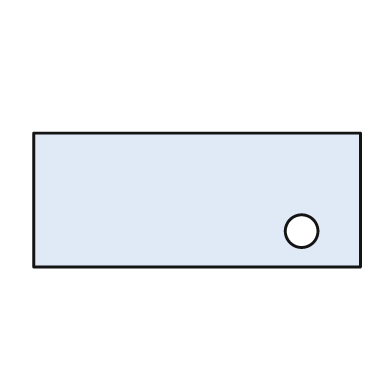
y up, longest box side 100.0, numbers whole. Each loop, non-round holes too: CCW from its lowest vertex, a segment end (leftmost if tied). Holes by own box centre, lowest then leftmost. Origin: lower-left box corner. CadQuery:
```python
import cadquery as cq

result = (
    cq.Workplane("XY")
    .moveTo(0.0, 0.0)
    .lineTo(100.0, 0.0)
    .lineTo(100.0, 41.0)
    .lineTo(0.0, 41.0)
    .close()
    .moveTo(82.0, 11.0)
    .circle(5.0)
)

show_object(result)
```